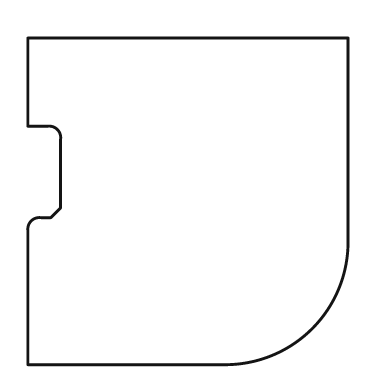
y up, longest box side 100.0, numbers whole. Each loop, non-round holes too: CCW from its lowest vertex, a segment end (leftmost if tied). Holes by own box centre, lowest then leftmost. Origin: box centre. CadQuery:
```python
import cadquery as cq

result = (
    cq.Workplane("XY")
    .moveTo(-49.0, -50.0)
    .lineTo(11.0, -50.0)
    .threePointArc((38.0, -39.0), (49.0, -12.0))
    .lineTo(49.0, 50.0)
    .lineTo(-49.0, 50.0)
    .lineTo(-49.0, 23.0)
    .lineTo(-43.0, 23.0)
    .threePointArc((-40.0, 22.0), (-39.0, 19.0))
    .lineTo(-39.0, -2.0)
    .lineTo(-42.0, -5.0)
    .lineTo(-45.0, -5.0)
    .threePointArc((-48.0, -6.0), (-49.0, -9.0))
    .close()
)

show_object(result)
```